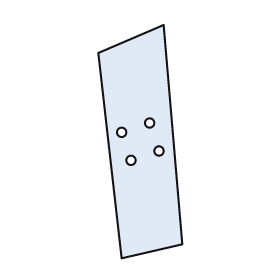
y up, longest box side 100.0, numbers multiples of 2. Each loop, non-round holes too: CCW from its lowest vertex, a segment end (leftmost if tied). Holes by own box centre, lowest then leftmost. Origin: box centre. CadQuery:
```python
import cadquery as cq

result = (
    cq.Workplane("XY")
    .moveTo(-8.0, -50.0)
    .lineTo(18.0, -44.0)
    .lineTo(10.0, 50.0)
    .lineTo(-18.0, 38.0)
    .close()
    .moveTo(-4.0, -8.0)
    .circle(2.0)
    .moveTo(8.0, -4.0)
    .circle(2.0)
    .moveTo(-8.0, 4.0)
    .circle(2.0)
    .moveTo(4.0, 8.0)
    .circle(2.0)
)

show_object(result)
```